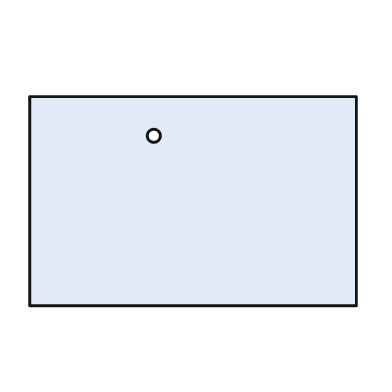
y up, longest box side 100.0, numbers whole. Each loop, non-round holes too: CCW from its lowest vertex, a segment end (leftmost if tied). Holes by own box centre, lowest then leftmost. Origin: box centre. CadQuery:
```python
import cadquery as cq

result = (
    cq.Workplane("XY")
    .moveTo(-50.0, -32.0)
    .lineTo(50.0, -32.0)
    .lineTo(50.0, 32.0)
    .lineTo(-50.0, 32.0)
    .close()
    .moveTo(-12.0, 20.0)
    .circle(2.0)
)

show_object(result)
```